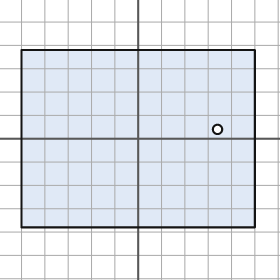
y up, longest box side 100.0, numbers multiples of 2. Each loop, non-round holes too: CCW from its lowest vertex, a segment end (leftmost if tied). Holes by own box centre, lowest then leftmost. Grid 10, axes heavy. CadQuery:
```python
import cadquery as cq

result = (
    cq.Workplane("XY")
    .moveTo(-50.0, -38.0)
    .lineTo(50.0, -38.0)
    .lineTo(50.0, 38.0)
    .lineTo(-50.0, 38.0)
    .close()
    .moveTo(34.0, 4.0)
    .circle(2.0)
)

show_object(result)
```